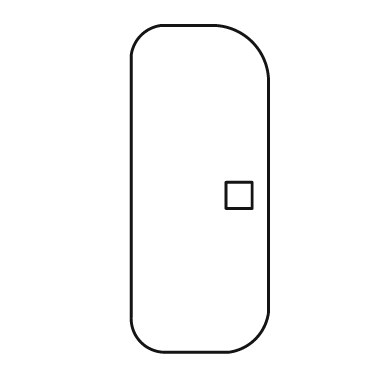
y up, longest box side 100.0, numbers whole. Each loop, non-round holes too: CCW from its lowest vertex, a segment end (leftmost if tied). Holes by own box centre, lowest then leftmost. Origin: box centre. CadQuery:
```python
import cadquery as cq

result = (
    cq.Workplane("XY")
    .moveTo(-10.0, -50.0)
    .lineTo(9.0, -50.0)
    .threePointArc((17.0, -46.0), (21.0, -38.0))
    .lineTo(21.0, 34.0)
    .threePointArc((16.0, 45.0), (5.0, 50.0))
    .lineTo(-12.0, 50.0)
    .threePointArc((-18.0, 47.0), (-21.0, 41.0))
    .lineTo(-21.0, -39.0)
    .threePointArc((-18.0, -47.0), (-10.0, -50.0))
    .close()
    .moveTo(8.0, -6.0)
    .lineTo(16.0, -6.0)
    .lineTo(16.0, 2.0)
    .lineTo(8.0, 2.0)
    .close()
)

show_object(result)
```